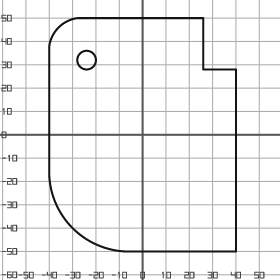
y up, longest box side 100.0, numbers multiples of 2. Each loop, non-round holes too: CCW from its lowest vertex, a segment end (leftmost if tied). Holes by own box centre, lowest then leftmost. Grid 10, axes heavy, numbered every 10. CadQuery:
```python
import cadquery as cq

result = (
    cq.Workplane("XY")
    .moveTo(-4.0, -50.0)
    .lineTo(40.0, -50.0)
    .lineTo(40.0, 28.0)
    .lineTo(26.0, 28.0)
    .lineTo(26.0, 50.0)
    .lineTo(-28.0, 50.0)
    .threePointArc((-36.0, 46.0), (-40.0, 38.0))
    .lineTo(-40.0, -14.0)
    .threePointArc((-30.0, -40.0), (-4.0, -50.0))
    .close()
    .moveTo(-24.0, 32.0)
    .circle(4.0)
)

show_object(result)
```